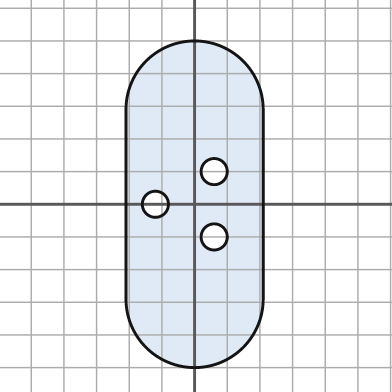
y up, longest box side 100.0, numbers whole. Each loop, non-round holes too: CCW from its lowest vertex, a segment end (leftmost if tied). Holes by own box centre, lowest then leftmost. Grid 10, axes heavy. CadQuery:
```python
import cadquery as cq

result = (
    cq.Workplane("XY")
    .moveTo(-21.0, -29.0)
    .threePointArc((0.0, -50.0), (21.0, -29.0))
    .lineTo(21.0, 29.0)
    .threePointArc((0.0, 50.0), (-21.0, 29.0))
    .close()
    .moveTo(6.0, -10.0)
    .circle(4.0)
    .moveTo(-12.0, 0.0)
    .circle(4.0)
    .moveTo(6.0, 10.0)
    .circle(4.0)
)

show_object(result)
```